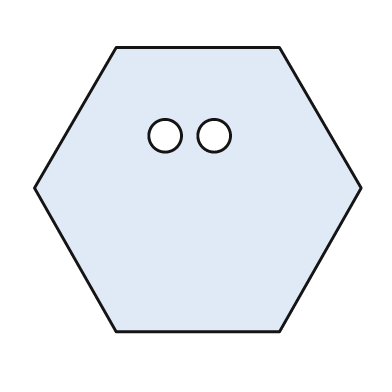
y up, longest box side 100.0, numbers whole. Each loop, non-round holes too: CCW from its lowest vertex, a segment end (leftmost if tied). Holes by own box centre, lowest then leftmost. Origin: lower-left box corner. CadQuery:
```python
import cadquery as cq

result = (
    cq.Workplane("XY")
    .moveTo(25.0, 0.0)
    .lineTo(75.0, 0.0)
    .lineTo(100.0, 44.0)
    .lineTo(75.0, 87.0)
    .lineTo(25.0, 87.0)
    .lineTo(0.0, 44.0)
    .close()
    .moveTo(40.0, 60.0)
    .circle(5.0)
    .moveTo(55.0, 60.0)
    .circle(5.0)
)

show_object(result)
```